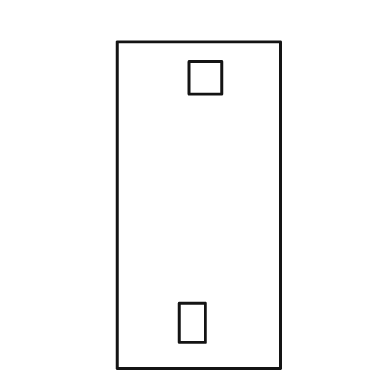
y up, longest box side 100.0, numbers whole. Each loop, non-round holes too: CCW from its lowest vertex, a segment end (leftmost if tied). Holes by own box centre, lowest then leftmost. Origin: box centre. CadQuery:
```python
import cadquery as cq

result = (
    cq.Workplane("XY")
    .moveTo(-25.0, -50.0)
    .lineTo(25.0, -50.0)
    .lineTo(25.0, 50.0)
    .lineTo(-25.0, 50.0)
    .close()
    .moveTo(-6.0, -42.0)
    .lineTo(2.0, -42.0)
    .lineTo(2.0, -30.0)
    .lineTo(-6.0, -30.0)
    .close()
    .moveTo(-3.0, 34.0)
    .lineTo(7.0, 34.0)
    .lineTo(7.0, 44.0)
    .lineTo(-3.0, 44.0)
    .close()
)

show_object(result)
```